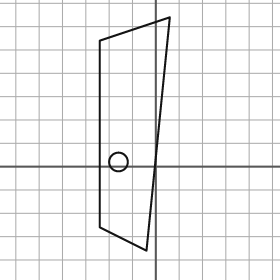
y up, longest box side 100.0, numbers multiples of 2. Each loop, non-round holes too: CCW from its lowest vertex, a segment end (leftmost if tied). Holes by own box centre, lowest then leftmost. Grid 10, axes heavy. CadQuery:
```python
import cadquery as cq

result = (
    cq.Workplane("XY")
    .moveTo(-4.0, -36.0)
    .lineTo(6.0, 64.0)
    .lineTo(-24.0, 54.0)
    .lineTo(-24.0, -26.0)
    .close()
    .moveTo(-16.0, 2.0)
    .circle(4.0)
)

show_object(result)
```